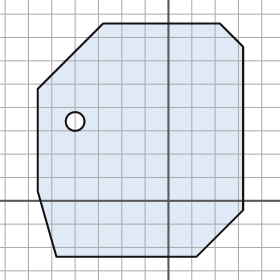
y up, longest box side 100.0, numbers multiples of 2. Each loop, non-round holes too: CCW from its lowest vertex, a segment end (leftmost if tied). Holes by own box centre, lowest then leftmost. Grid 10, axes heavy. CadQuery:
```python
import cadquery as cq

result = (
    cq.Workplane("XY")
    .moveTo(-48.0, -24.0)
    .lineTo(12.0, -24.0)
    .lineTo(32.0, -4.0)
    .lineTo(32.0, 66.0)
    .lineTo(22.0, 76.0)
    .lineTo(-28.0, 76.0)
    .lineTo(-56.0, 48.0)
    .lineTo(-56.0, 4.0)
    .close()
    .moveTo(-40.0, 34.0)
    .circle(4.0)
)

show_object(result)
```